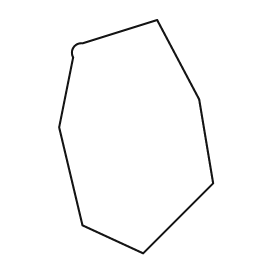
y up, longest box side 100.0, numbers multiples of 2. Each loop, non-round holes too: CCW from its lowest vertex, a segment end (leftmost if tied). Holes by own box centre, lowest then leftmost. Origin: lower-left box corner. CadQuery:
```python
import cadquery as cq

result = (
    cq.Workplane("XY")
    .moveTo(36.0, 0.0)
    .lineTo(66.0, 30.0)
    .lineTo(60.0, 66.0)
    .lineTo(42.0, 100.0)
    .lineTo(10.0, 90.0)
    .threePointArc((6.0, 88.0), (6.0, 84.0))
    .lineTo(0.0, 54.0)
    .lineTo(10.0, 12.0)
    .close()
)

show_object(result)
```